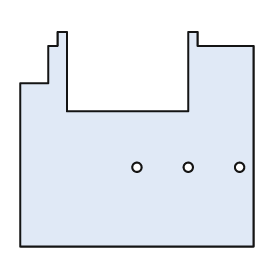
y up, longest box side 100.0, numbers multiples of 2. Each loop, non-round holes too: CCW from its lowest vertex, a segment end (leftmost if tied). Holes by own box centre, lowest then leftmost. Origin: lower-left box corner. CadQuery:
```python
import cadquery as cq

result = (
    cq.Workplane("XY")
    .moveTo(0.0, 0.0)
    .lineTo(100.0, 0.0)
    .lineTo(100.0, 86.0)
    .lineTo(76.0, 86.0)
    .lineTo(76.0, 92.0)
    .lineTo(72.0, 92.0)
    .lineTo(72.0, 58.0)
    .lineTo(20.0, 58.0)
    .lineTo(20.0, 92.0)
    .lineTo(16.0, 92.0)
    .lineTo(16.0, 86.0)
    .lineTo(12.0, 86.0)
    .lineTo(12.0, 70.0)
    .lineTo(0.0, 70.0)
    .close()
    .moveTo(50.0, 34.0)
    .circle(2.0)
    .moveTo(72.0, 34.0)
    .circle(2.0)
    .moveTo(94.0, 34.0)
    .circle(2.0)
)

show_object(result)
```